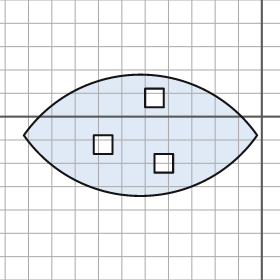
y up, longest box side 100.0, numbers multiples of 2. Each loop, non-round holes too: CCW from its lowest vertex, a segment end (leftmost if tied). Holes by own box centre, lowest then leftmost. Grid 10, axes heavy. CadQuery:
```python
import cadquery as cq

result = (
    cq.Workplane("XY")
    .moveTo(-102.0, -8.0)
    .threePointArc((-52.0, -34.0), (-2.0, -8.0))
    .threePointArc((-52.0, 18.0), (-102.0, -8.0))
    .close()
    .moveTo(-46.0, -24.0)
    .lineTo(-38.0, -24.0)
    .lineTo(-38.0, -16.0)
    .lineTo(-46.0, -16.0)
    .close()
    .moveTo(-72.0, -16.0)
    .lineTo(-64.0, -16.0)
    .lineTo(-64.0, -8.0)
    .lineTo(-72.0, -8.0)
    .close()
    .moveTo(-50.0, 4.0)
    .lineTo(-42.0, 4.0)
    .lineTo(-42.0, 12.0)
    .lineTo(-50.0, 12.0)
    .close()
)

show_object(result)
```